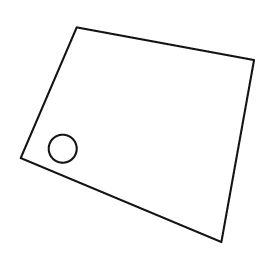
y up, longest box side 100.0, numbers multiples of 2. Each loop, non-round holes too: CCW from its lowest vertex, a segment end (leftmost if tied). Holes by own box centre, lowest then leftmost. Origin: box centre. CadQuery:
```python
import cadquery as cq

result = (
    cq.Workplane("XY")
    .moveTo(36.0, -46.0)
    .lineTo(50.0, 32.0)
    .lineTo(-26.0, 46.0)
    .lineTo(-50.0, -10.0)
    .close()
    .moveTo(-32.0, -6.0)
    .circle(6.0)
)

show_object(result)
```